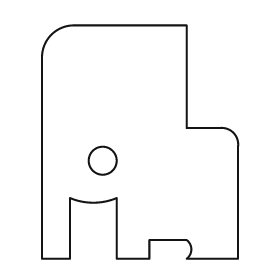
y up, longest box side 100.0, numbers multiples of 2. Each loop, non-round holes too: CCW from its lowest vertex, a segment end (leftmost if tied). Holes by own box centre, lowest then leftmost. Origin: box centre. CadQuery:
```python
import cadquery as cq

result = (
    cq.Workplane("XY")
    .moveTo(-42.0, -50.0)
    .lineTo(-30.0, -50.0)
    .lineTo(-30.0, -24.0)
    .threePointArc((-20.0, -26.0), (-10.0, -24.0))
    .lineTo(-10.0, -50.0)
    .lineTo(4.0, -50.0)
    .lineTo(4.0, -42.0)
    .lineTo(20.0, -42.0)
    .threePointArc((22.0, -46.0), (20.0, -50.0))
    .lineTo(42.0, -50.0)
    .lineTo(42.0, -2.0)
    .threePointArc((40.0, 4.0), (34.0, 6.0))
    .lineTo(20.0, 6.0)
    .lineTo(20.0, 50.0)
    .lineTo(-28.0, 50.0)
    .threePointArc((-38.0, 46.0), (-42.0, 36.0))
    .close()
    .moveTo(-16.0, -8.0)
    .circle(6.0)
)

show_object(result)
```